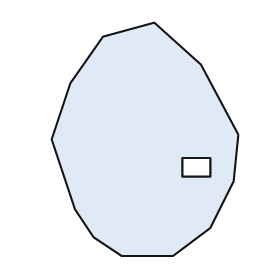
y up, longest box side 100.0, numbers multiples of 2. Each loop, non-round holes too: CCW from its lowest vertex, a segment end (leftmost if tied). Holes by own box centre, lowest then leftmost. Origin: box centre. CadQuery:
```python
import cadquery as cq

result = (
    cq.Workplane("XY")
    .moveTo(-10.0, -50.0)
    .lineTo(12.0, -50.0)
    .lineTo(28.0, -38.0)
    .lineTo(38.0, -18.0)
    .lineTo(40.0, 2.0)
    .lineTo(24.0, 32.0)
    .lineTo(4.0, 50.0)
    .lineTo(-18.0, 44.0)
    .lineTo(-32.0, 24.0)
    .lineTo(-40.0, 0.0)
    .lineTo(-30.0, -30.0)
    .lineTo(-22.0, -42.0)
    .close()
    .moveTo(16.0, -16.0)
    .lineTo(28.0, -16.0)
    .lineTo(28.0, -8.0)
    .lineTo(16.0, -8.0)
    .close()
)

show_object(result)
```